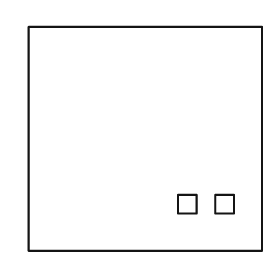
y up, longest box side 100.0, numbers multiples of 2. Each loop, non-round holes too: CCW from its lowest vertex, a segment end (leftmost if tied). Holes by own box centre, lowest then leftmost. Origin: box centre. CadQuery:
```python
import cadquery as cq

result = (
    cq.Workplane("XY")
    .moveTo(-50.0, -48.0)
    .lineTo(50.0, -48.0)
    .lineTo(50.0, 48.0)
    .lineTo(-50.0, 48.0)
    .close()
    .moveTo(14.0, -32.0)
    .lineTo(22.0, -32.0)
    .lineTo(22.0, -24.0)
    .lineTo(14.0, -24.0)
    .close()
    .moveTo(30.0, -32.0)
    .lineTo(38.0, -32.0)
    .lineTo(38.0, -24.0)
    .lineTo(30.0, -24.0)
    .close()
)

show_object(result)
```